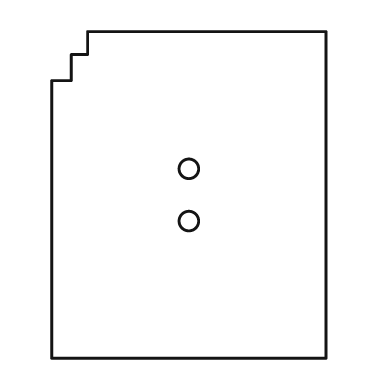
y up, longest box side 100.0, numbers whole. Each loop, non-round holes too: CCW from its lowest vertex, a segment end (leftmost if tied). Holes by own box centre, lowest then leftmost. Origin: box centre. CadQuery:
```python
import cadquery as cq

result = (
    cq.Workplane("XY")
    .moveTo(-42.0, -50.0)
    .lineTo(42.0, -50.0)
    .lineTo(42.0, 50.0)
    .lineTo(-31.0, 50.0)
    .lineTo(-31.0, 43.0)
    .lineTo(-36.0, 43.0)
    .lineTo(-36.0, 35.0)
    .lineTo(-42.0, 35.0)
    .close()
    .moveTo(0.0, -8.0)
    .circle(3.0)
    .moveTo(0.0, 8.0)
    .circle(3.0)
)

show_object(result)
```